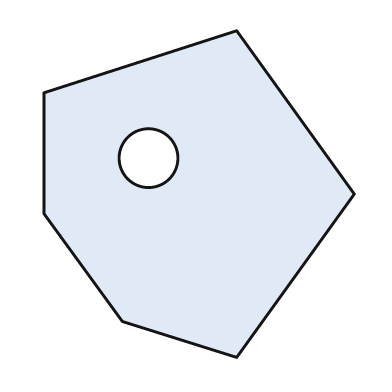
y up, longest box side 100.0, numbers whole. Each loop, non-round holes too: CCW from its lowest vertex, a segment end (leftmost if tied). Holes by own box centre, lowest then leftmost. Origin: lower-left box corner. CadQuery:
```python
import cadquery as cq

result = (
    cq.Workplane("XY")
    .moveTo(59.0, 0.0)
    .lineTo(95.0, 50.0)
    .lineTo(59.0, 100.0)
    .lineTo(0.0, 81.0)
    .lineTo(0.0, 44.0)
    .lineTo(24.0, 11.0)
    .close()
    .moveTo(32.0, 61.0)
    .circle(9.0)
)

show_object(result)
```